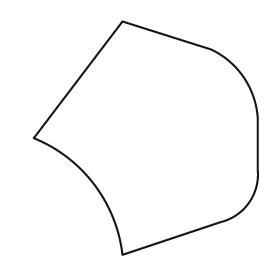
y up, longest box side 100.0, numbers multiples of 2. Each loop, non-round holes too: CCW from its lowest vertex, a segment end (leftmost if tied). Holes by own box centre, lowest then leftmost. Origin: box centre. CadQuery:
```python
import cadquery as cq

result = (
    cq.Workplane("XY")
    .moveTo(-10.0, -50.0)
    .lineTo(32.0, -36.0)
    .threePointArc((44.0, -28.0), (48.0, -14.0))
    .lineTo(48.0, 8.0)
    .threePointArc((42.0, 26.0), (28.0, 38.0))
    .lineTo(-10.0, 50.0)
    .lineTo(-48.0, 0.0)
    .threePointArc((-22.0, -20.0), (-10.0, -50.0))
    .close()
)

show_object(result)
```